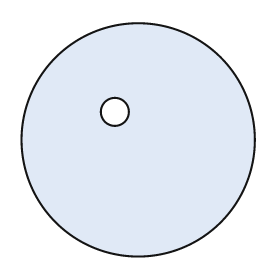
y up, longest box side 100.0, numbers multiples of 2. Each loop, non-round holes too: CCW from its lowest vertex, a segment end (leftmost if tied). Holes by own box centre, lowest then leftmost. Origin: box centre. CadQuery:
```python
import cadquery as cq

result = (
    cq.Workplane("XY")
    .moveTo(0.0, 0.0)
    .circle(50.0)
    .moveTo(-10.0, 12.0)
    .circle(6.0)
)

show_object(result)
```